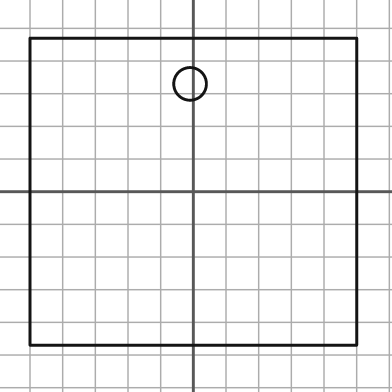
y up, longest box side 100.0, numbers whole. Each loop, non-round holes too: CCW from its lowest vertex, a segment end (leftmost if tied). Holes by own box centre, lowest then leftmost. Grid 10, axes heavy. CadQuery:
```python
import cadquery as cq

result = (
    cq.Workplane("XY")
    .moveTo(-50.0, -47.0)
    .lineTo(50.0, -47.0)
    .lineTo(50.0, 47.0)
    .lineTo(-50.0, 47.0)
    .close()
    .moveTo(-1.0, 33.0)
    .circle(5.0)
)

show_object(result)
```